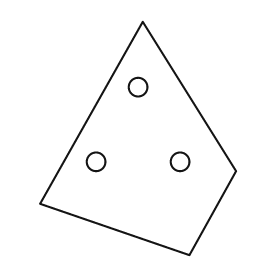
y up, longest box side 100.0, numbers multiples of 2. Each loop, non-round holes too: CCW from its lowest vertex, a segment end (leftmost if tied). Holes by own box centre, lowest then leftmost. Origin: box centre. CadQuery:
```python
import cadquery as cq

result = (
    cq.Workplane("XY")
    .moveTo(22.0, -50.0)
    .lineTo(42.0, -14.0)
    .lineTo(2.0, 50.0)
    .lineTo(-42.0, -28.0)
    .close()
    .moveTo(-18.0, -10.0)
    .circle(4.0)
    .moveTo(18.0, -10.0)
    .circle(4.0)
    .moveTo(0.0, 22.0)
    .circle(4.0)
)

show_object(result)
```